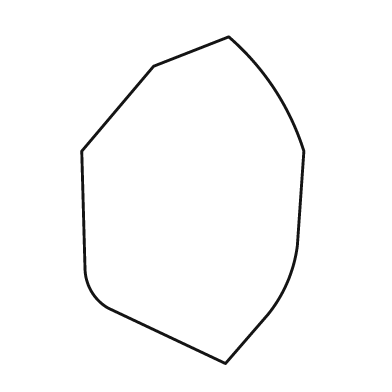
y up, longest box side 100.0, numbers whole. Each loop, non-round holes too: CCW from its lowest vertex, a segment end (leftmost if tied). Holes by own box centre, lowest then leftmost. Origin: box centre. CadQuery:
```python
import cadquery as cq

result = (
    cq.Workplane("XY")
    .moveTo(10.0, -50.0)
    .lineTo(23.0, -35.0)
    .threePointArc((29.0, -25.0), (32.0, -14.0))
    .lineTo(34.0, 15.0)
    .threePointArc((25.0, 34.0), (11.0, 50.0))
    .lineTo(-12.0, 41.0)
    .lineTo(-34.0, 15.0)
    .lineTo(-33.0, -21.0)
    .threePointArc((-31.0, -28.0), (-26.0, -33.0))
    .close()
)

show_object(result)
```